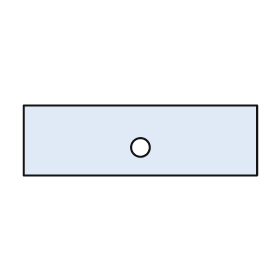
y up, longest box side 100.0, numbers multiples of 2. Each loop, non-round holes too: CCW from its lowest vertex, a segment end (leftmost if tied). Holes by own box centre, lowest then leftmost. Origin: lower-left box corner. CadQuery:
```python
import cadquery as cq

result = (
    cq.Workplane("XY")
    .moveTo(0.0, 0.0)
    .lineTo(100.0, 0.0)
    .lineTo(100.0, 30.0)
    .lineTo(0.0, 30.0)
    .close()
    .moveTo(50.0, 12.0)
    .circle(4.0)
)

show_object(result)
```